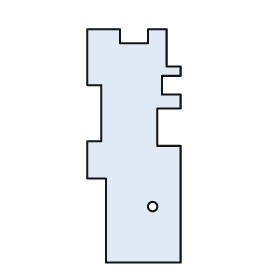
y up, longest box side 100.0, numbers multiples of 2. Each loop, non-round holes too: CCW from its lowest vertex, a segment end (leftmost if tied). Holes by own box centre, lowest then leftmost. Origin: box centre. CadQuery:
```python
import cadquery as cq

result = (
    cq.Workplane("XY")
    .moveTo(-12.0, -50.0)
    .lineTo(20.0, -50.0)
    .lineTo(20.0, 0.0)
    .lineTo(10.0, 0.0)
    .lineTo(10.0, 16.0)
    .lineTo(20.0, 16.0)
    .lineTo(20.0, 22.0)
    .lineTo(12.0, 22.0)
    .lineTo(12.0, 30.0)
    .lineTo(20.0, 30.0)
    .lineTo(20.0, 34.0)
    .lineTo(14.0, 34.0)
    .lineTo(14.0, 50.0)
    .lineTo(6.0, 50.0)
    .lineTo(6.0, 44.0)
    .lineTo(-6.0, 44.0)
    .lineTo(-6.0, 50.0)
    .lineTo(-20.0, 50.0)
    .lineTo(-20.0, 26.0)
    .lineTo(-14.0, 26.0)
    .lineTo(-14.0, 2.0)
    .lineTo(-20.0, 2.0)
    .lineTo(-20.0, -14.0)
    .lineTo(-12.0, -14.0)
    .close()
    .moveTo(8.0, -26.0)
    .circle(2.0)
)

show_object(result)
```